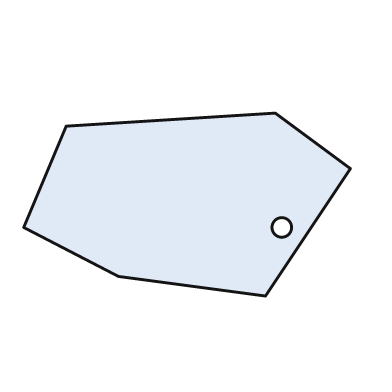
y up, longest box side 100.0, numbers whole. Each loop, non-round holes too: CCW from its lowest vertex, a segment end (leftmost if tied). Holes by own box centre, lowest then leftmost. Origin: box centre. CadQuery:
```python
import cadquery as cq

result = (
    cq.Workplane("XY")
    .moveTo(24.0, -28.0)
    .lineTo(50.0, 11.0)
    .lineTo(27.0, 28.0)
    .lineTo(-37.0, 24.0)
    .lineTo(-50.0, -7.0)
    .lineTo(-21.0, -22.0)
    .close()
    .moveTo(29.0, -7.0)
    .circle(3.0)
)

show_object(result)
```